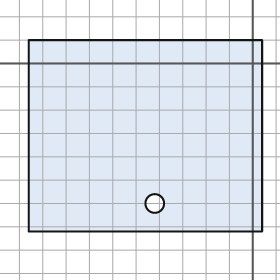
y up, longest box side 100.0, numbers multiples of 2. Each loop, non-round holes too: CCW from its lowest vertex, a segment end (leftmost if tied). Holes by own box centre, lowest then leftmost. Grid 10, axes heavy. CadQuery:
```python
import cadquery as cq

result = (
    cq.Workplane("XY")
    .moveTo(-96.0, -72.0)
    .lineTo(4.0, -72.0)
    .lineTo(4.0, 10.0)
    .lineTo(-96.0, 10.0)
    .close()
    .moveTo(-42.0, -60.0)
    .circle(4.0)
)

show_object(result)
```